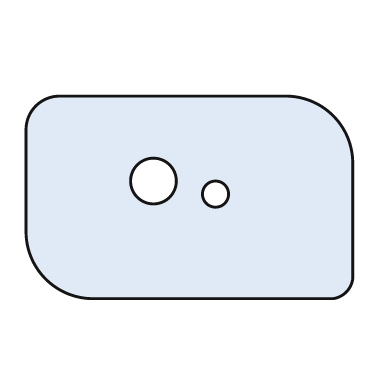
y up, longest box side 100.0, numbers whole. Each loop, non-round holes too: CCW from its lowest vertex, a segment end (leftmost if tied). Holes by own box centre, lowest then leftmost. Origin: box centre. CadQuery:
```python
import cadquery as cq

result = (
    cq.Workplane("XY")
    .moveTo(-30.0, -31.0)
    .lineTo(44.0, -31.0)
    .threePointArc((48.0, -29.0), (50.0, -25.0))
    .lineTo(50.0, 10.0)
    .threePointArc((44.0, 25.0), (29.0, 31.0))
    .lineTo(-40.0, 31.0)
    .threePointArc((-47.0, 28.0), (-50.0, 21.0))
    .lineTo(-50.0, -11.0)
    .threePointArc((-44.0, -25.0), (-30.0, -31.0))
    .close()
    .moveTo(8.0, 1.0)
    .circle(4.0)
    .moveTo(-11.0, 5.0)
    .circle(7.0)
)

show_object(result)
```